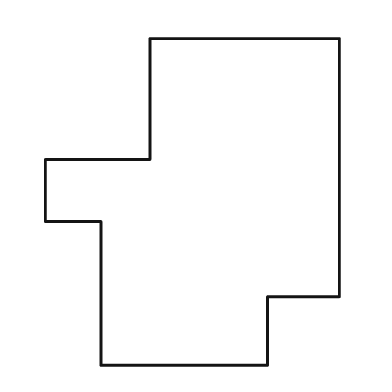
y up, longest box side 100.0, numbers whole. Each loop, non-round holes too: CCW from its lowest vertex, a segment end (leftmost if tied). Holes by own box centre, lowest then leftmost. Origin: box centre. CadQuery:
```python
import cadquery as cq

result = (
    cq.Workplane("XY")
    .moveTo(-28.0, -50.0)
    .lineTo(23.0, -50.0)
    .lineTo(23.0, -29.0)
    .lineTo(45.0, -29.0)
    .lineTo(45.0, 50.0)
    .lineTo(-13.0, 50.0)
    .lineTo(-13.0, 13.0)
    .lineTo(-45.0, 13.0)
    .lineTo(-45.0, -6.0)
    .lineTo(-28.0, -6.0)
    .close()
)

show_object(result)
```